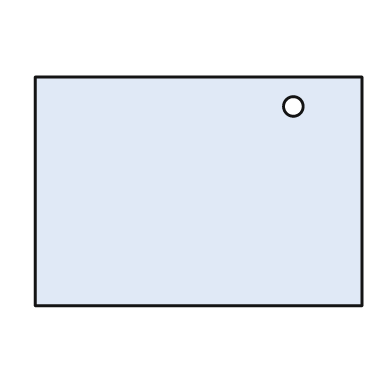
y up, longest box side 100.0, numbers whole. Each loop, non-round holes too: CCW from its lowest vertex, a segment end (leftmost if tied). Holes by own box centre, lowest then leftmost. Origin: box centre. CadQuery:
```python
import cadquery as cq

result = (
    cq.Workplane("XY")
    .moveTo(-50.0, -35.0)
    .lineTo(50.0, -35.0)
    .lineTo(50.0, 35.0)
    .lineTo(-50.0, 35.0)
    .close()
    .moveTo(29.0, 26.0)
    .circle(3.0)
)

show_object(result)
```